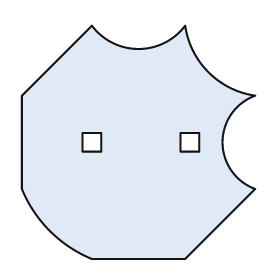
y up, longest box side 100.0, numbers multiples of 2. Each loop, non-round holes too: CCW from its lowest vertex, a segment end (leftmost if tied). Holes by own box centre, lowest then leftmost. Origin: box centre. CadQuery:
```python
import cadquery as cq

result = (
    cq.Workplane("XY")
    .moveTo(-20.0, -50.0)
    .lineTo(20.0, -50.0)
    .lineTo(50.0, -20.0)
    .threePointArc((36.0, 0.0), (50.0, 20.0))
    .threePointArc((30.0, 30.0), (20.0, 50.0))
    .threePointArc((0.0, 40.0), (-20.0, 50.0))
    .lineTo(-50.0, 20.0)
    .lineTo(-50.0, -20.0)
    .threePointArc((-38.0, -38.0), (-20.0, -50.0))
    .close()
    .moveTo(-24.0, -4.0)
    .lineTo(-16.0, -4.0)
    .lineTo(-16.0, 4.0)
    .lineTo(-24.0, 4.0)
    .close()
    .moveTo(18.0, -4.0)
    .lineTo(26.0, -4.0)
    .lineTo(26.0, 4.0)
    .lineTo(18.0, 4.0)
    .close()
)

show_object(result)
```